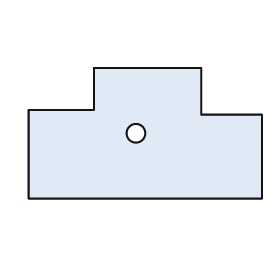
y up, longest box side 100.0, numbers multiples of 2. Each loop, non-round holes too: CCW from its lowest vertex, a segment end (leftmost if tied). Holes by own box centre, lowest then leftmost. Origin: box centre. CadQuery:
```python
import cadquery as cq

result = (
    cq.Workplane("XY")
    .moveTo(-50.0, -28.0)
    .lineTo(50.0, -28.0)
    .lineTo(50.0, 8.0)
    .lineTo(24.0, 8.0)
    .lineTo(24.0, 28.0)
    .lineTo(-22.0, 28.0)
    .lineTo(-22.0, 10.0)
    .lineTo(-50.0, 10.0)
    .close()
    .moveTo(-4.0, 0.0)
    .circle(4.0)
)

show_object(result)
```